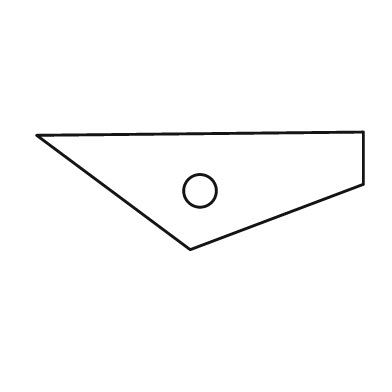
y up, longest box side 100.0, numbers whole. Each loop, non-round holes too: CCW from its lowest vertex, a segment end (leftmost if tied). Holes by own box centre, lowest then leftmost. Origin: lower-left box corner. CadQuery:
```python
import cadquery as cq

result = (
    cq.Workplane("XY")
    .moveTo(47.0, 0.0)
    .lineTo(100.0, 20.0)
    .lineTo(100.0, 36.0)
    .lineTo(0.0, 35.0)
    .close()
    .moveTo(50.0, 18.0)
    .circle(5.0)
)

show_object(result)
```